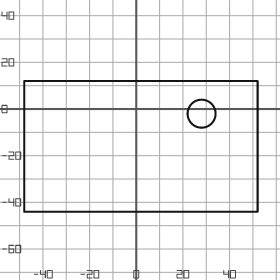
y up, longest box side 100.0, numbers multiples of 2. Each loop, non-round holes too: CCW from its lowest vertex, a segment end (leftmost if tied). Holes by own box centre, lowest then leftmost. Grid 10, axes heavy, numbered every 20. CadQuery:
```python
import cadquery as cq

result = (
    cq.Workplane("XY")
    .moveTo(-48.0, -44.0)
    .lineTo(52.0, -44.0)
    .lineTo(52.0, 12.0)
    .lineTo(-48.0, 12.0)
    .close()
    .moveTo(28.0, -2.0)
    .circle(6.0)
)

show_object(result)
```